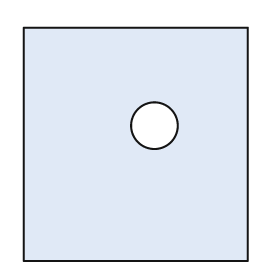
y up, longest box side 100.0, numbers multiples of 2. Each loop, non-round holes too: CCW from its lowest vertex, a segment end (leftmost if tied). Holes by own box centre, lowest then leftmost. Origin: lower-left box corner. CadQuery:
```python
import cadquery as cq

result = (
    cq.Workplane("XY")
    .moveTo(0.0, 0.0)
    .lineTo(96.0, 0.0)
    .lineTo(96.0, 100.0)
    .lineTo(0.0, 100.0)
    .close()
    .moveTo(56.0, 58.0)
    .circle(10.0)
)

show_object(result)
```